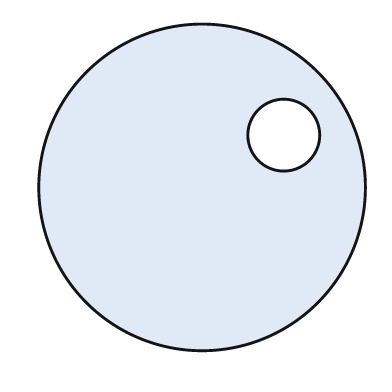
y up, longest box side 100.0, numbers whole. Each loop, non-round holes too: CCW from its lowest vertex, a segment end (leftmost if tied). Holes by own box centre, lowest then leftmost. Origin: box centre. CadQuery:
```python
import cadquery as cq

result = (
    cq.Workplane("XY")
    .moveTo(0.0, 0.0)
    .circle(50.0)
    .moveTo(25.0, 16.0)
    .circle(11.0)
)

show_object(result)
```